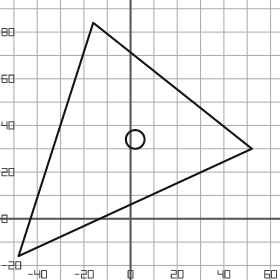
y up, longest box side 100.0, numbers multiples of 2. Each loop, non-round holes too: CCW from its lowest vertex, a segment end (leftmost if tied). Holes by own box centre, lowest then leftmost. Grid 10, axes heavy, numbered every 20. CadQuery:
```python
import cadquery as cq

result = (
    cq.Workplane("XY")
    .moveTo(-48.0, -16.0)
    .lineTo(52.0, 30.0)
    .lineTo(-16.0, 84.0)
    .close()
    .moveTo(2.0, 34.0)
    .circle(4.0)
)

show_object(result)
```